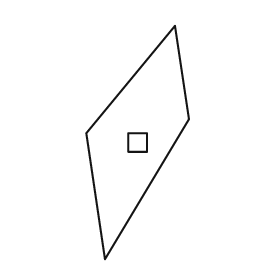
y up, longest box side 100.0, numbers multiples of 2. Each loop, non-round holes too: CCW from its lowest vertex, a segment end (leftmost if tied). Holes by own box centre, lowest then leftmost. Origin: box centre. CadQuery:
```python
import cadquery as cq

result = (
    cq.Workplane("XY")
    .moveTo(-14.0, -50.0)
    .lineTo(22.0, 10.0)
    .lineTo(16.0, 50.0)
    .lineTo(-22.0, 4.0)
    .close()
    .moveTo(-4.0, -4.0)
    .lineTo(4.0, -4.0)
    .lineTo(4.0, 4.0)
    .lineTo(-4.0, 4.0)
    .close()
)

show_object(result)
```